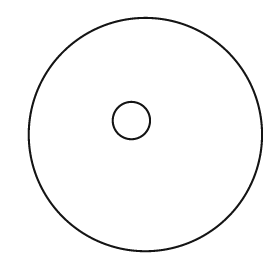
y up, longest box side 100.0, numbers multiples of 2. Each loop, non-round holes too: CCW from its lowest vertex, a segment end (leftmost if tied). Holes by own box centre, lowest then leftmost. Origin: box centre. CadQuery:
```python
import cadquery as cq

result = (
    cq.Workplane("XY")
    .moveTo(0.0, 0.0)
    .circle(50.0)
    .moveTo(-6.0, 6.0)
    .circle(8.0)
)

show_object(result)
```